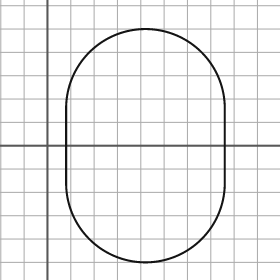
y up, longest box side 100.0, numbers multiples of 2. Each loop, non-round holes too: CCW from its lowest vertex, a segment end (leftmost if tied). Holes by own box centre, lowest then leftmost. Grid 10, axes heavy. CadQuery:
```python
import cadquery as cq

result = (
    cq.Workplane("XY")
    .moveTo(8.0, -16.0)
    .threePointArc((42.0, -50.0), (76.0, -16.0))
    .lineTo(76.0, 16.0)
    .threePointArc((42.0, 50.0), (8.0, 16.0))
    .close()
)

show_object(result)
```